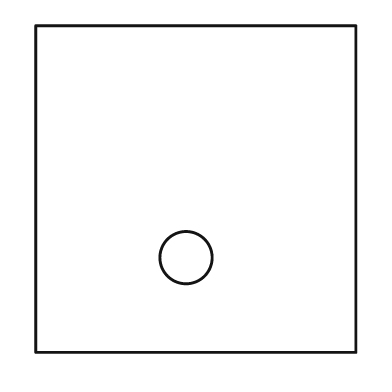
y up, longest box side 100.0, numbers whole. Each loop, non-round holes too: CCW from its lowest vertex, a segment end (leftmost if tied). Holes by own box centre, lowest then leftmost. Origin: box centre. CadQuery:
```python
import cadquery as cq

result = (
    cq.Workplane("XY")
    .moveTo(-49.0, -50.0)
    .lineTo(49.0, -50.0)
    .lineTo(49.0, 50.0)
    .lineTo(-49.0, 50.0)
    .close()
    .moveTo(-3.0, -21.0)
    .circle(8.0)
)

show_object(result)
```